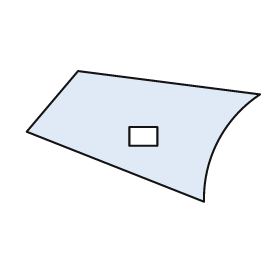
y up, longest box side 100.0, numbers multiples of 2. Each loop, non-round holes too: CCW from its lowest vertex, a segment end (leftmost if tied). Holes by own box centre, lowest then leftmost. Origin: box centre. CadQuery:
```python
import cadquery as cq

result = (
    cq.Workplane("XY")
    .moveTo(26.0, -28.0)
    .threePointArc((32.0, -2.0), (50.0, 18.0))
    .lineTo(-28.0, 28.0)
    .lineTo(-50.0, 2.0)
    .close()
    .moveTo(-6.0, -4.0)
    .lineTo(6.0, -4.0)
    .lineTo(6.0, 4.0)
    .lineTo(-6.0, 4.0)
    .close()
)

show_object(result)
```